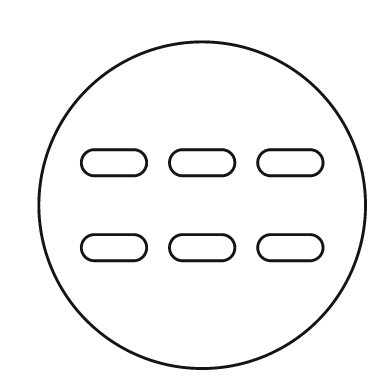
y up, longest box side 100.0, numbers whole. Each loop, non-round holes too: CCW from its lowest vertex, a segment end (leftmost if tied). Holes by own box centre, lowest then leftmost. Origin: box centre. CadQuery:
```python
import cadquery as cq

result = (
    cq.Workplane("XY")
    .moveTo(0.0, 0.0)
    .circle(50.0)
    .moveTo(-33.0, -17.0)
    .lineTo(-21.0, -17.0)
    .threePointArc((-17.0, -13.0), (-21.0, -9.0))
    .lineTo(-33.0, -9.0)
    .threePointArc((-37.0, -13.0), (-33.0, -17.0))
    .close()
    .moveTo(-6.0, -17.0)
    .lineTo(6.0, -17.0)
    .threePointArc((10.0, -13.0), (6.0, -9.0))
    .lineTo(-6.0, -9.0)
    .threePointArc((-10.0, -13.0), (-6.0, -17.0))
    .close()
    .moveTo(21.0, -17.0)
    .lineTo(33.0, -17.0)
    .threePointArc((37.0, -13.0), (33.0, -9.0))
    .lineTo(21.0, -9.0)
    .threePointArc((17.0, -13.0), (21.0, -17.0))
    .close()
    .moveTo(-33.0, 9.0)
    .lineTo(-21.0, 9.0)
    .threePointArc((-17.0, 13.0), (-21.0, 17.0))
    .lineTo(-33.0, 17.0)
    .threePointArc((-37.0, 13.0), (-33.0, 9.0))
    .close()
    .moveTo(-6.0, 9.0)
    .lineTo(6.0, 9.0)
    .threePointArc((10.0, 13.0), (6.0, 17.0))
    .lineTo(-6.0, 17.0)
    .threePointArc((-10.0, 13.0), (-6.0, 9.0))
    .close()
    .moveTo(21.0, 9.0)
    .lineTo(33.0, 9.0)
    .threePointArc((37.0, 13.0), (33.0, 17.0))
    .lineTo(21.0, 17.0)
    .threePointArc((17.0, 13.0), (21.0, 9.0))
    .close()
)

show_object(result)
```